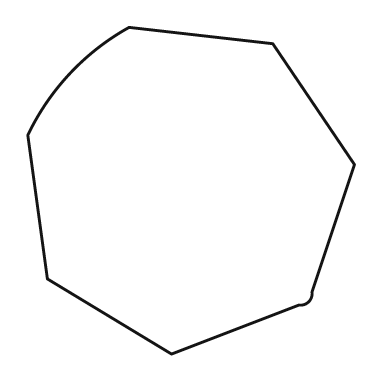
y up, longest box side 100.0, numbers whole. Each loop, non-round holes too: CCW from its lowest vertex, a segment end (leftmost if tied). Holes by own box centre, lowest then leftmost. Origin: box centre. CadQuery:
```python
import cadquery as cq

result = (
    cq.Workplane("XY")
    .moveTo(-6.0, -50.0)
    .lineTo(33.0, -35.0)
    .threePointArc((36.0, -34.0), (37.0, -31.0))
    .lineTo(50.0, 8.0)
    .lineTo(25.0, 45.0)
    .lineTo(-19.0, 50.0)
    .threePointArc((-37.0, 36.0), (-50.0, 17.0))
    .lineTo(-44.0, -27.0)
    .close()
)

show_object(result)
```